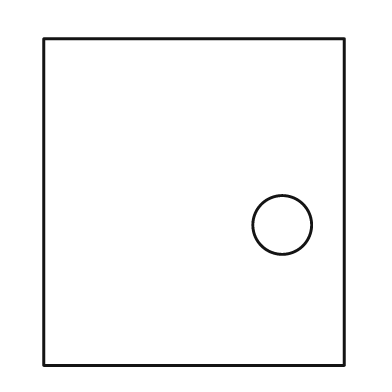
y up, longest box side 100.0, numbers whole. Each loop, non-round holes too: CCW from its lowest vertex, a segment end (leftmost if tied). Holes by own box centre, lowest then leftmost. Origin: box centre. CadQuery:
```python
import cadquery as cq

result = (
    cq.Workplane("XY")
    .moveTo(-46.0, -50.0)
    .lineTo(46.0, -50.0)
    .lineTo(46.0, 50.0)
    .lineTo(-46.0, 50.0)
    .close()
    .moveTo(27.0, -7.0)
    .circle(9.0)
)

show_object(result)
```